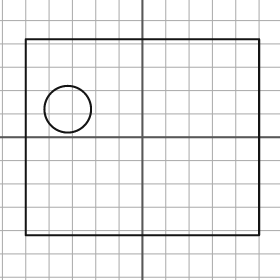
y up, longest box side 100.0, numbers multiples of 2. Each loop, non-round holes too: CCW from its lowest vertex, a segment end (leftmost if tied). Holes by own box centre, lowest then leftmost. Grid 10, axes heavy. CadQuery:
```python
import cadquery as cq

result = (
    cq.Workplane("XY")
    .moveTo(-50.0, -42.0)
    .lineTo(50.0, -42.0)
    .lineTo(50.0, 42.0)
    .lineTo(-50.0, 42.0)
    .close()
    .moveTo(-32.0, 12.0)
    .circle(10.0)
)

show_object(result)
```